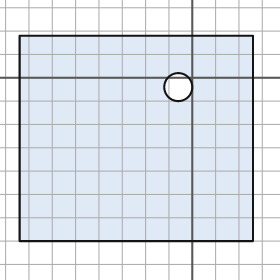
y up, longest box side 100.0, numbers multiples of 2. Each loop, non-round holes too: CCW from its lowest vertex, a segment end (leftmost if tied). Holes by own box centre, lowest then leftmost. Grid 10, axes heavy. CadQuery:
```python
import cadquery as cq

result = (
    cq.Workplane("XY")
    .moveTo(-74.0, -70.0)
    .lineTo(26.0, -70.0)
    .lineTo(26.0, 18.0)
    .lineTo(-74.0, 18.0)
    .close()
    .moveTo(-6.0, -4.0)
    .circle(6.0)
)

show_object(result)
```